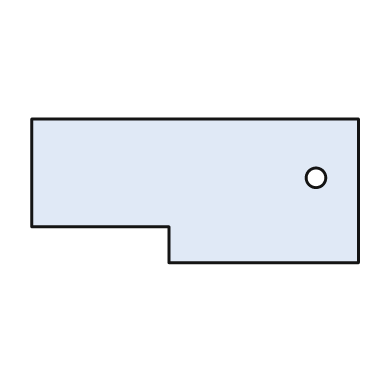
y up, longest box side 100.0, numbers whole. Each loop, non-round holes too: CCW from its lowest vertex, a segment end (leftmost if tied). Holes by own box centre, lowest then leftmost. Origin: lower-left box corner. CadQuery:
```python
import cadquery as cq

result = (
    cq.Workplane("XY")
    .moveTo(42.0, 0.0)
    .lineTo(100.0, 0.0)
    .lineTo(100.0, 44.0)
    .lineTo(0.0, 44.0)
    .lineTo(0.0, 11.0)
    .lineTo(42.0, 11.0)
    .close()
    .moveTo(87.0, 26.0)
    .circle(3.0)
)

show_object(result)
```